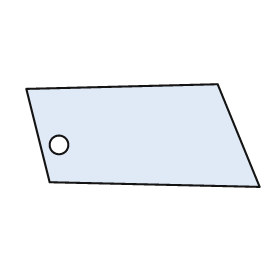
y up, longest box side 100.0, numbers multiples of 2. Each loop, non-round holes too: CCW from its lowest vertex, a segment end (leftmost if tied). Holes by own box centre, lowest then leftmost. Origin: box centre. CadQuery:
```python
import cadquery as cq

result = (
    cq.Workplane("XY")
    .moveTo(50.0, -22.0)
    .lineTo(32.0, 22.0)
    .lineTo(-50.0, 20.0)
    .lineTo(-40.0, -20.0)
    .close()
    .moveTo(-36.0, -4.0)
    .circle(4.0)
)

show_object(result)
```